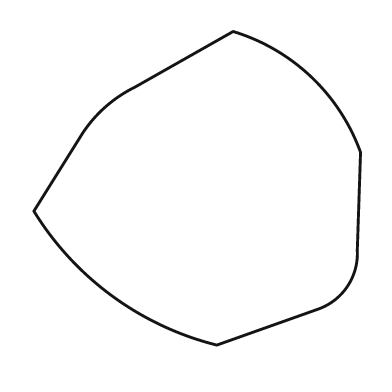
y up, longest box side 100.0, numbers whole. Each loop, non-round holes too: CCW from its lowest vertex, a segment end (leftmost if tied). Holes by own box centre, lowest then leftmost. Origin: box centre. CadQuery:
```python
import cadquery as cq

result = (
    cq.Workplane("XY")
    .moveTo(6.0, -48.0)
    .lineTo(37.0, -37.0)
    .threePointArc((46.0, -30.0), (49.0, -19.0))
    .lineTo(50.0, 11.0)
    .threePointArc((35.0, 34.0), (11.0, 48.0))
    .lineTo(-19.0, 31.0)
    .threePointArc((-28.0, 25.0), (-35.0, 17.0))
    .lineTo(-50.0, -7.0)
    .threePointArc((-26.0, -33.0), (6.0, -48.0))
    .close()
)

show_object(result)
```